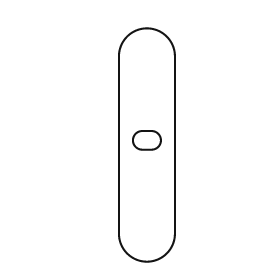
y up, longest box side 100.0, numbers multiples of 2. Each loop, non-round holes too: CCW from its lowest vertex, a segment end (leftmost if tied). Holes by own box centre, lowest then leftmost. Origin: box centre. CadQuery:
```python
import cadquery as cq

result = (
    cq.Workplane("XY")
    .moveTo(-12.0, -38.0)
    .threePointArc((0.0, -50.0), (12.0, -38.0))
    .lineTo(12.0, 38.0)
    .threePointArc((0.0, 50.0), (-12.0, 38.0))
    .close()
    .moveTo(-2.0, -2.0)
    .lineTo(2.0, -2.0)
    .threePointArc((6.0, 2.0), (2.0, 6.0))
    .lineTo(-2.0, 6.0)
    .threePointArc((-6.0, 2.0), (-2.0, -2.0))
    .close()
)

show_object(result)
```